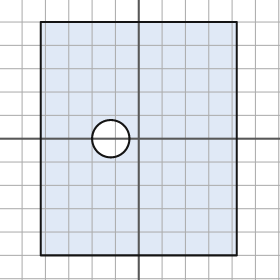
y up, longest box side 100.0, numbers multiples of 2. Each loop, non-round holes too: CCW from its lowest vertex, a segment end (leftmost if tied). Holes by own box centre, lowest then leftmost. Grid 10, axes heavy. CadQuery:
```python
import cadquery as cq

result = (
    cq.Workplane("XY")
    .moveTo(-42.0, -50.0)
    .lineTo(42.0, -50.0)
    .lineTo(42.0, 50.0)
    .lineTo(-42.0, 50.0)
    .close()
    .moveTo(-12.0, 0.0)
    .circle(8.0)
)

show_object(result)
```